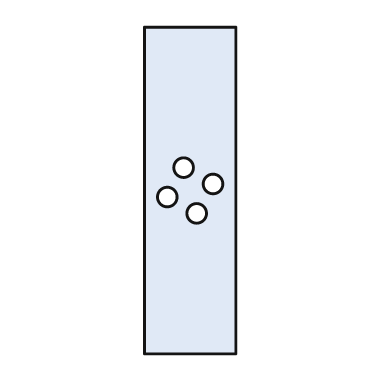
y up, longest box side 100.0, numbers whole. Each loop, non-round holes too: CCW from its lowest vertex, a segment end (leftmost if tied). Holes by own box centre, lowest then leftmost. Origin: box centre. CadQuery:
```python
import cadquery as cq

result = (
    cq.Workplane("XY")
    .moveTo(-14.0, -50.0)
    .lineTo(14.0, -50.0)
    .lineTo(14.0, 50.0)
    .lineTo(-14.0, 50.0)
    .close()
    .moveTo(2.0, -7.0)
    .circle(3.0)
    .moveTo(-7.0, -2.0)
    .circle(3.0)
    .moveTo(7.0, 2.0)
    .circle(3.0)
    .moveTo(-2.0, 7.0)
    .circle(3.0)
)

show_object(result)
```